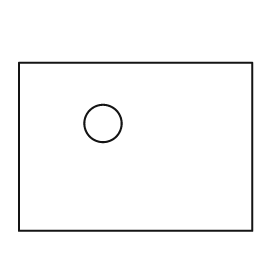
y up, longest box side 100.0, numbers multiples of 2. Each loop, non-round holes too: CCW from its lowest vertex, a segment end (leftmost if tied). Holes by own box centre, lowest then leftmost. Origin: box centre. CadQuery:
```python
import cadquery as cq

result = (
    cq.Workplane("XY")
    .moveTo(-50.0, -36.0)
    .lineTo(50.0, -36.0)
    .lineTo(50.0, 36.0)
    .lineTo(-50.0, 36.0)
    .close()
    .moveTo(-14.0, 10.0)
    .circle(8.0)
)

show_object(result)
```